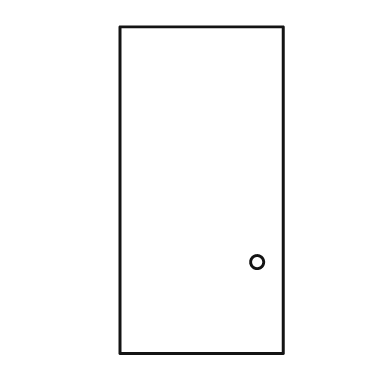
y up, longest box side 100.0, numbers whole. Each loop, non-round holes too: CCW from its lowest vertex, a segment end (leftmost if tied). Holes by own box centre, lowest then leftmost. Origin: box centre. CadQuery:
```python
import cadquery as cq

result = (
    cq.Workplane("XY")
    .moveTo(-25.0, -50.0)
    .lineTo(25.0, -50.0)
    .lineTo(25.0, 50.0)
    .lineTo(-25.0, 50.0)
    .close()
    .moveTo(17.0, -22.0)
    .circle(2.0)
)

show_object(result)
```